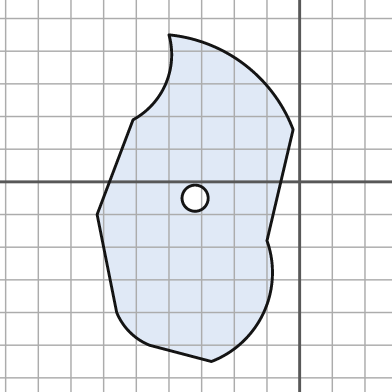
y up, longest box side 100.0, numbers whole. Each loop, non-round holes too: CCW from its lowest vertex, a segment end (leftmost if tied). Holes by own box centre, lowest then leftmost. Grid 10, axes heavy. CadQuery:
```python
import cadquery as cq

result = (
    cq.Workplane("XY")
    .moveTo(-27.0, -55.0)
    .threePointArc((-11.0, -40.0), (-10.0, -18.0))
    .lineTo(-2.0, 16.0)
    .threePointArc((-17.0, 36.0), (-40.0, 45.0))
    .threePointArc((-41.0, 30.0), (-51.0, 19.0))
    .lineTo(-62.0, -10.0)
    .lineTo(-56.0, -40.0)
    .threePointArc((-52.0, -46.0), (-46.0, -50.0))
    .close()
    .moveTo(-32.0, -5.0)
    .circle(4.0)
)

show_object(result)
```